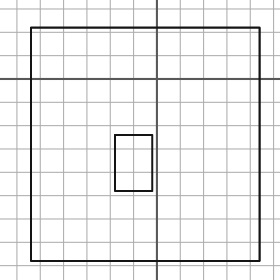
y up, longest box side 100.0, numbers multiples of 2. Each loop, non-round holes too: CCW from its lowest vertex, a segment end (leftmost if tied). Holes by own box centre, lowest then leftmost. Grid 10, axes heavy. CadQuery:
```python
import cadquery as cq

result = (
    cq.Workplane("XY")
    .moveTo(-54.0, -78.0)
    .lineTo(44.0, -78.0)
    .lineTo(44.0, 22.0)
    .lineTo(-54.0, 22.0)
    .close()
    .moveTo(-18.0, -48.0)
    .lineTo(-2.0, -48.0)
    .lineTo(-2.0, -24.0)
    .lineTo(-18.0, -24.0)
    .close()
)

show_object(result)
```